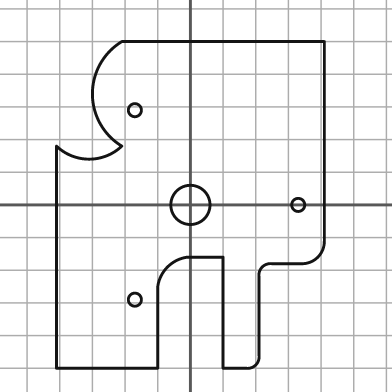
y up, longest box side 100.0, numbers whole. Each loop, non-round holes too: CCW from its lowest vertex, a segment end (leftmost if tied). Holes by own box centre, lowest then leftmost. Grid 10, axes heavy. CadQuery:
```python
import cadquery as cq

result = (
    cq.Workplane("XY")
    .moveTo(-41.0, -50.0)
    .lineTo(-10.0, -50.0)
    .lineTo(-10.0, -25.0)
    .threePointArc((-7.0, -19.0), (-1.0, -16.0))
    .lineTo(10.0, -16.0)
    .lineTo(10.0, -50.0)
    .lineTo(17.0, -50.0)
    .threePointArc((20.0, -49.0), (21.0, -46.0))
    .lineTo(21.0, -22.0)
    .threePointArc((22.0, -19.0), (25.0, -18.0))
    .lineTo(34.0, -18.0)
    .threePointArc((39.0, -16.0), (41.0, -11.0))
    .lineTo(41.0, 50.0)
    .lineTo(-21.0, 50.0)
    .threePointArc((-30.0, 34.0), (-21.0, 18.0))
    .threePointArc((-31.0, 14.0), (-41.0, 18.0))
    .close()
    .moveTo(-17.0, -29.0)
    .circle(2.0)
    .moveTo(0.0, 0.0)
    .circle(6.0)
    .moveTo(33.0, 0.0)
    .circle(2.0)
    .moveTo(-17.0, 29.0)
    .circle(2.0)
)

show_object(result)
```